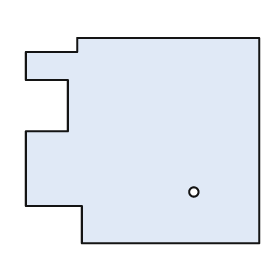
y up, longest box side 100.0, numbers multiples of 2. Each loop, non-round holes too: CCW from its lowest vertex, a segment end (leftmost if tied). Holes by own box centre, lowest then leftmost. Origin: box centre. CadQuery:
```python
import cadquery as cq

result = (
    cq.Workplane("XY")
    .moveTo(-26.0, -44.0)
    .lineTo(50.0, -44.0)
    .lineTo(50.0, 44.0)
    .lineTo(-28.0, 44.0)
    .lineTo(-28.0, 38.0)
    .lineTo(-50.0, 38.0)
    .lineTo(-50.0, 26.0)
    .lineTo(-32.0, 26.0)
    .lineTo(-32.0, 4.0)
    .lineTo(-50.0, 4.0)
    .lineTo(-50.0, -28.0)
    .lineTo(-26.0, -28.0)
    .close()
    .moveTo(22.0, -22.0)
    .circle(2.0)
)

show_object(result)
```